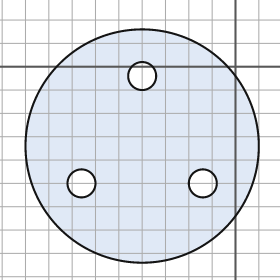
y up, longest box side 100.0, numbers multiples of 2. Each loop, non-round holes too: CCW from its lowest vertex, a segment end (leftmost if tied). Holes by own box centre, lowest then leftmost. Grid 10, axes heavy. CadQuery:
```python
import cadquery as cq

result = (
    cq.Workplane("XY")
    .moveTo(-40.0, -34.0)
    .circle(50.0)
    .moveTo(-66.0, -50.0)
    .circle(6.0)
    .moveTo(-14.0, -50.0)
    .circle(6.0)
    .moveTo(-40.0, -4.0)
    .circle(6.0)
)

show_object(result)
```